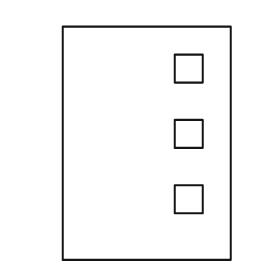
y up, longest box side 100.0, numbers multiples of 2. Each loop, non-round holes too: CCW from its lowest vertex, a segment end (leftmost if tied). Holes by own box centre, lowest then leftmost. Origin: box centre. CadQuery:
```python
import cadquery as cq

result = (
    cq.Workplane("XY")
    .moveTo(-36.0, -50.0)
    .lineTo(36.0, -50.0)
    .lineTo(36.0, 50.0)
    .lineTo(-36.0, 50.0)
    .close()
    .moveTo(12.0, -30.0)
    .lineTo(24.0, -30.0)
    .lineTo(24.0, -18.0)
    .lineTo(12.0, -18.0)
    .close()
    .moveTo(12.0, -2.0)
    .lineTo(24.0, -2.0)
    .lineTo(24.0, 10.0)
    .lineTo(12.0, 10.0)
    .close()
    .moveTo(12.0, 26.0)
    .lineTo(24.0, 26.0)
    .lineTo(24.0, 38.0)
    .lineTo(12.0, 38.0)
    .close()
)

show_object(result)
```